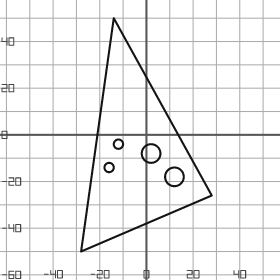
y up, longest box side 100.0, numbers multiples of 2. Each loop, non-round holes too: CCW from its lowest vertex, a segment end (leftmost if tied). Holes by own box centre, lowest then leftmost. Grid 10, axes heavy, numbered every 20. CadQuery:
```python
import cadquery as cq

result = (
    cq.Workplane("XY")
    .moveTo(-28.0, -50.0)
    .lineTo(28.0, -26.0)
    .lineTo(-14.0, 50.0)
    .close()
    .moveTo(12.0, -18.0)
    .circle(4.0)
    .moveTo(-16.0, -14.0)
    .circle(2.0)
    .moveTo(2.0, -8.0)
    .circle(4.0)
    .moveTo(-12.0, -4.0)
    .circle(2.0)
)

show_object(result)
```